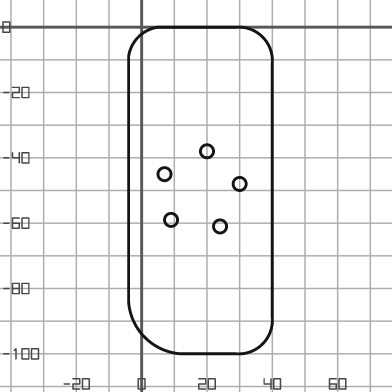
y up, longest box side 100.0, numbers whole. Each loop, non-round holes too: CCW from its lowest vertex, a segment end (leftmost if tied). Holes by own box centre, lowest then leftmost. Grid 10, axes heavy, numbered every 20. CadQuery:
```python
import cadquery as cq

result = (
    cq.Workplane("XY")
    .moveTo(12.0, -100.0)
    .lineTo(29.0, -100.0)
    .threePointArc((37.0, -97.0), (40.0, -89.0))
    .lineTo(40.0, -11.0)
    .threePointArc((37.0, -3.0), (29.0, 0.0))
    .lineTo(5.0, 0.0)
    .threePointArc((-1.0, -3.0), (-4.0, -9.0))
    .lineTo(-4.0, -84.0)
    .threePointArc((1.0, -95.0), (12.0, -100.0))
    .close()
    .moveTo(24.0, -61.0)
    .circle(2.0)
    .moveTo(9.0, -59.0)
    .circle(2.0)
    .moveTo(30.0, -48.0)
    .circle(2.0)
    .moveTo(7.0, -45.0)
    .circle(2.0)
    .moveTo(20.0, -38.0)
    .circle(2.0)
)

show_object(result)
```